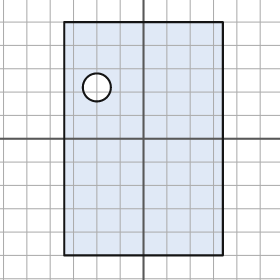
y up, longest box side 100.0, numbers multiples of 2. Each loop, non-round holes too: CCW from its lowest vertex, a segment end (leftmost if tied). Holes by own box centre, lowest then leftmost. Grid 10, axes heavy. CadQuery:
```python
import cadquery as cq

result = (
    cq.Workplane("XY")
    .moveTo(-34.0, -50.0)
    .lineTo(34.0, -50.0)
    .lineTo(34.0, 50.0)
    .lineTo(-34.0, 50.0)
    .close()
    .moveTo(-20.0, 22.0)
    .circle(6.0)
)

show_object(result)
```